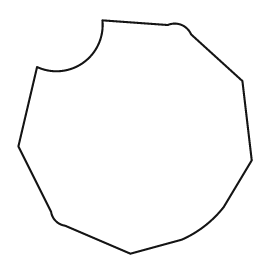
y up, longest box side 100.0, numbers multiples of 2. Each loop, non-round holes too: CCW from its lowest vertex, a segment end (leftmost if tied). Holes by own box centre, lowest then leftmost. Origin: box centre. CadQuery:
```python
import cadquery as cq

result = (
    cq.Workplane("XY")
    .moveTo(-2.0, -50.0)
    .lineTo(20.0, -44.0)
    .threePointArc((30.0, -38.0), (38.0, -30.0))
    .lineTo(50.0, -10.0)
    .lineTo(46.0, 24.0)
    .lineTo(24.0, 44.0)
    .threePointArc((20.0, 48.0), (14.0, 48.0))
    .lineTo(-14.0, 50.0)
    .threePointArc((-22.0, 32.0), (-42.0, 30.0))
    .lineTo(-50.0, -4.0)
    .lineTo(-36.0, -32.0)
    .threePointArc((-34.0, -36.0), (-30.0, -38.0))
    .close()
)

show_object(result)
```